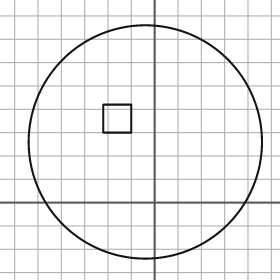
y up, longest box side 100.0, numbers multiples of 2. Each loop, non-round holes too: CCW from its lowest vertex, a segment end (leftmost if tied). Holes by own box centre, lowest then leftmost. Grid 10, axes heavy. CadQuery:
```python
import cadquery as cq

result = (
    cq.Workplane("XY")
    .moveTo(-4.0, 26.0)
    .circle(50.0)
    .moveTo(-22.0, 30.0)
    .lineTo(-10.0, 30.0)
    .lineTo(-10.0, 42.0)
    .lineTo(-22.0, 42.0)
    .close()
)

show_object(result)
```